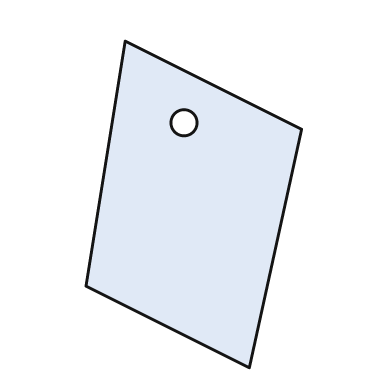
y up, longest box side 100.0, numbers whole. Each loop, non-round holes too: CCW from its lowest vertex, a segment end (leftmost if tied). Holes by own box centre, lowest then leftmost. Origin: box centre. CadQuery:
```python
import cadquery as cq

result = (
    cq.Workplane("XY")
    .moveTo(17.0, -50.0)
    .lineTo(33.0, 23.0)
    .lineTo(-21.0, 50.0)
    .lineTo(-33.0, -25.0)
    .close()
    .moveTo(-3.0, 25.0)
    .circle(4.0)
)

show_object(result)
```